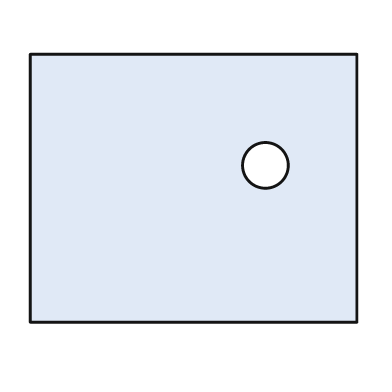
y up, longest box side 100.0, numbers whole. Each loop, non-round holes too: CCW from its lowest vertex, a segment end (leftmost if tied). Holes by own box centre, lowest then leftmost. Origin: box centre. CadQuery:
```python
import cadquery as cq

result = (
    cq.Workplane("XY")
    .moveTo(-50.0, -41.0)
    .lineTo(50.0, -41.0)
    .lineTo(50.0, 41.0)
    .lineTo(-50.0, 41.0)
    .close()
    .moveTo(22.0, 7.0)
    .circle(7.0)
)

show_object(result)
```